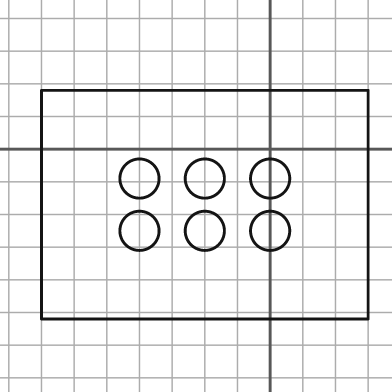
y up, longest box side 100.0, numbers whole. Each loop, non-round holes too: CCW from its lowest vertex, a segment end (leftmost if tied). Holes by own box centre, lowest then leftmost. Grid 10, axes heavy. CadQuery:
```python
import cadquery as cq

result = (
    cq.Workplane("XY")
    .moveTo(-70.0, -52.0)
    .lineTo(30.0, -52.0)
    .lineTo(30.0, 18.0)
    .lineTo(-70.0, 18.0)
    .close()
    .moveTo(-40.0, -25.0)
    .circle(6.0)
    .moveTo(-20.0, -25.0)
    .circle(6.0)
    .moveTo(0.0, -25.0)
    .circle(6.0)
    .moveTo(-40.0, -9.0)
    .circle(6.0)
    .moveTo(-20.0, -9.0)
    .circle(6.0)
    .moveTo(0.0, -9.0)
    .circle(6.0)
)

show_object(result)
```